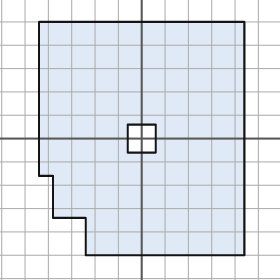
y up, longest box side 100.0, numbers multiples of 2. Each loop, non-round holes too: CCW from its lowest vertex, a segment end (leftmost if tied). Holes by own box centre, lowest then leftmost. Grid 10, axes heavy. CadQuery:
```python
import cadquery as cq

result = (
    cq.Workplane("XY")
    .moveTo(-24.0, -50.0)
    .lineTo(44.0, -50.0)
    .lineTo(44.0, 50.0)
    .lineTo(-44.0, 50.0)
    .lineTo(-44.0, -16.0)
    .lineTo(-38.0, -16.0)
    .lineTo(-38.0, -34.0)
    .lineTo(-24.0, -34.0)
    .close()
    .moveTo(-6.0, -6.0)
    .lineTo(6.0, -6.0)
    .lineTo(6.0, 6.0)
    .lineTo(-6.0, 6.0)
    .close()
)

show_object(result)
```